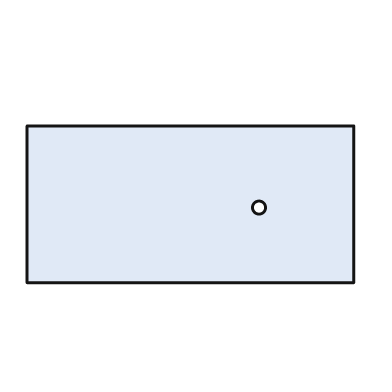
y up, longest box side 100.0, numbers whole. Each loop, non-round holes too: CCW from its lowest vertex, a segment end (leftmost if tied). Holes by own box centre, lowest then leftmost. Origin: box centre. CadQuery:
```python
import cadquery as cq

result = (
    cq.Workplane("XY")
    .moveTo(-50.0, -24.0)
    .lineTo(50.0, -24.0)
    .lineTo(50.0, 24.0)
    .lineTo(-50.0, 24.0)
    .close()
    .moveTo(21.0, -1.0)
    .circle(2.0)
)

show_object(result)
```